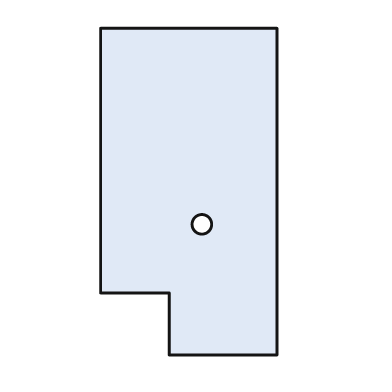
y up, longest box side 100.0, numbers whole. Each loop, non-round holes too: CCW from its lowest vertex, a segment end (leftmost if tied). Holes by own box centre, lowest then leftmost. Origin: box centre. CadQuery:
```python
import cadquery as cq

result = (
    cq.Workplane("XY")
    .moveTo(-6.0, -50.0)
    .lineTo(27.0, -50.0)
    .lineTo(27.0, 50.0)
    .lineTo(-27.0, 50.0)
    .lineTo(-27.0, -31.0)
    .lineTo(-6.0, -31.0)
    .close()
    .moveTo(4.0, -10.0)
    .circle(3.0)
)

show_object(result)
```